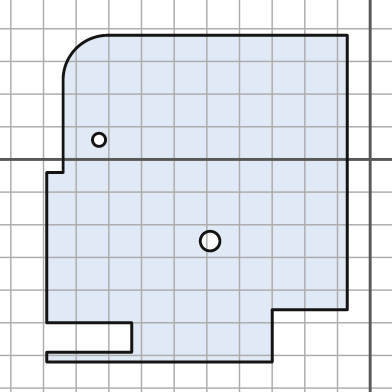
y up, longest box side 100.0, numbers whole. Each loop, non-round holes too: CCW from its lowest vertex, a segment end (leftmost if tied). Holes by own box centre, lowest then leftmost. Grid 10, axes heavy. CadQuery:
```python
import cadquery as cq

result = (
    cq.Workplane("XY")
    .moveTo(-99.0, -62.0)
    .lineTo(-30.0, -62.0)
    .lineTo(-30.0, -46.0)
    .lineTo(-7.0, -46.0)
    .lineTo(-7.0, 38.0)
    .lineTo(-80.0, 38.0)
    .threePointArc((-90.0, 34.0), (-94.0, 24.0))
    .lineTo(-94.0, -4.0)
    .lineTo(-99.0, -4.0)
    .lineTo(-99.0, -50.0)
    .lineTo(-73.0, -50.0)
    .lineTo(-73.0, -59.0)
    .lineTo(-99.0, -59.0)
    .close()
    .moveTo(-49.0, -25.0)
    .circle(3.0)
    .moveTo(-83.0, 6.0)
    .circle(2.0)
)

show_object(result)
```